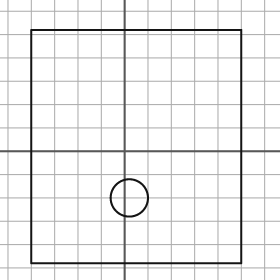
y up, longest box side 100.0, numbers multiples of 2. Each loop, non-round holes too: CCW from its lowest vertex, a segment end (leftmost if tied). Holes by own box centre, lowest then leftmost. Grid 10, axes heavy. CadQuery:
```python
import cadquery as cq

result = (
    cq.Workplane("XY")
    .moveTo(-40.0, -48.0)
    .lineTo(50.0, -48.0)
    .lineTo(50.0, 52.0)
    .lineTo(-40.0, 52.0)
    .close()
    .moveTo(2.0, -20.0)
    .circle(8.0)
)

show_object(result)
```